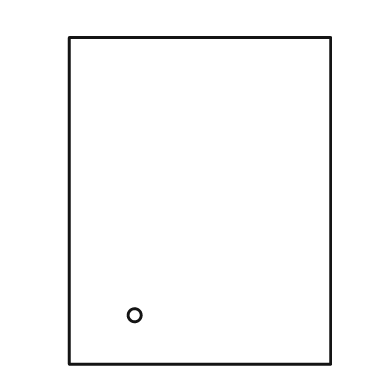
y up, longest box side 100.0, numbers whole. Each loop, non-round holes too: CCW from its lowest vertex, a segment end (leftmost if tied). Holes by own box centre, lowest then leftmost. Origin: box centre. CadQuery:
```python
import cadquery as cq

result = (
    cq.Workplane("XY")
    .moveTo(-40.0, -50.0)
    .lineTo(40.0, -50.0)
    .lineTo(40.0, 50.0)
    .lineTo(-40.0, 50.0)
    .close()
    .moveTo(-20.0, -35.0)
    .circle(2.0)
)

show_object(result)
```